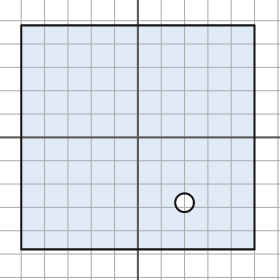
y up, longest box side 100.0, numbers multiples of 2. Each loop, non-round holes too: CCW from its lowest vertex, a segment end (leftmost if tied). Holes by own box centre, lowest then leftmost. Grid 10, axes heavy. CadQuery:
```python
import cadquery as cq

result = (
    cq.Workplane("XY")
    .moveTo(-50.0, -48.0)
    .lineTo(50.0, -48.0)
    .lineTo(50.0, 48.0)
    .lineTo(-50.0, 48.0)
    .close()
    .moveTo(20.0, -28.0)
    .circle(4.0)
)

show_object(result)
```